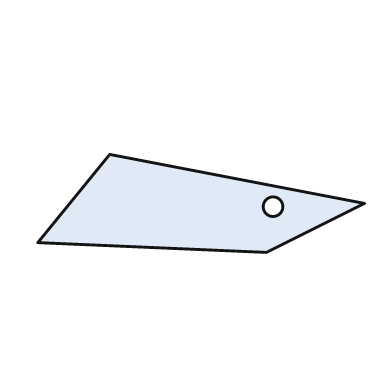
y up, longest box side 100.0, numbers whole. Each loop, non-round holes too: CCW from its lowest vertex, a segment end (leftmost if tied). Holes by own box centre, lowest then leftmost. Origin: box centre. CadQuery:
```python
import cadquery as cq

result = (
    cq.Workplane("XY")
    .moveTo(20.0, -15.0)
    .lineTo(50.0, 0.0)
    .lineTo(-28.0, 15.0)
    .lineTo(-50.0, -12.0)
    .close()
    .moveTo(22.0, -1.0)
    .circle(3.0)
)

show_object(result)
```